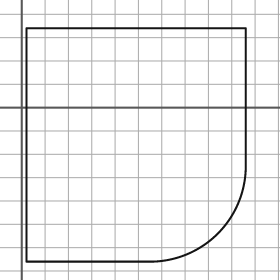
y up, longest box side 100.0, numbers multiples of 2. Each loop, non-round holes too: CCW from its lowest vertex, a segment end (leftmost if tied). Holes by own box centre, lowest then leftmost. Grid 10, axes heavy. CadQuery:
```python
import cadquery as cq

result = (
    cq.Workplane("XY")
    .moveTo(2.0, -66.0)
    .lineTo(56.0, -66.0)
    .threePointArc((84.0, -54.0), (96.0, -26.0))
    .lineTo(96.0, 34.0)
    .lineTo(2.0, 34.0)
    .close()
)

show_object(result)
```